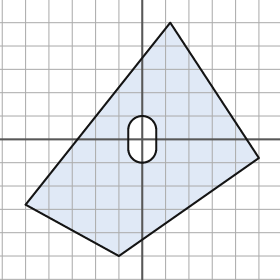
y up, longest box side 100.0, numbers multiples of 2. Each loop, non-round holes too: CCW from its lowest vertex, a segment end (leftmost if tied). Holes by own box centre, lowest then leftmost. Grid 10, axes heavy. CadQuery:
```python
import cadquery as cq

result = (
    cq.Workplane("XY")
    .moveTo(-10.0, -50.0)
    .lineTo(50.0, -8.0)
    .lineTo(12.0, 50.0)
    .lineTo(-50.0, -28.0)
    .close()
    .moveTo(-6.0, -4.0)
    .threePointArc((0.0, -10.0), (6.0, -4.0))
    .lineTo(6.0, 4.0)
    .threePointArc((0.0, 10.0), (-6.0, 4.0))
    .close()
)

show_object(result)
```